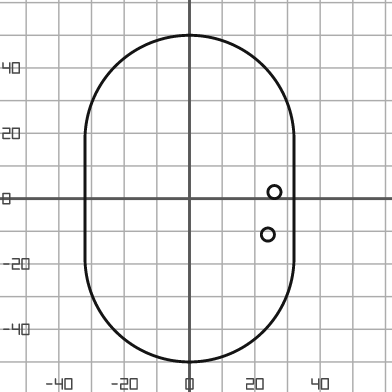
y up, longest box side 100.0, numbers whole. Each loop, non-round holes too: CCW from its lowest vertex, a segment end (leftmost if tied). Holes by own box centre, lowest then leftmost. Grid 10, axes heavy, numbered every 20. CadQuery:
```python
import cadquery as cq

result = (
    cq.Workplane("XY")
    .moveTo(-32.0, -18.0)
    .threePointArc((0.0, -50.0), (32.0, -18.0))
    .lineTo(32.0, 18.0)
    .threePointArc((0.0, 50.0), (-32.0, 18.0))
    .close()
    .moveTo(24.0, -11.0)
    .circle(2.0)
    .moveTo(26.0, 2.0)
    .circle(2.0)
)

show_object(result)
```